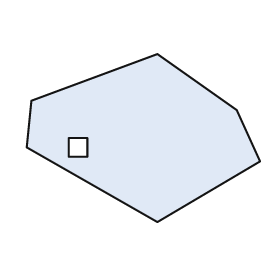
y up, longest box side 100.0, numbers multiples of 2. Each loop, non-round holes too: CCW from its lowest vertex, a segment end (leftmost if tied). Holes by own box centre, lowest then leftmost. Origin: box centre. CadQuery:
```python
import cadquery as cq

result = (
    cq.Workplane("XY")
    .moveTo(6.0, -36.0)
    .lineTo(50.0, -10.0)
    .lineTo(40.0, 12.0)
    .lineTo(6.0, 36.0)
    .lineTo(-48.0, 16.0)
    .lineTo(-50.0, -4.0)
    .close()
    .moveTo(-32.0, -8.0)
    .lineTo(-24.0, -8.0)
    .lineTo(-24.0, 0.0)
    .lineTo(-32.0, 0.0)
    .close()
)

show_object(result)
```